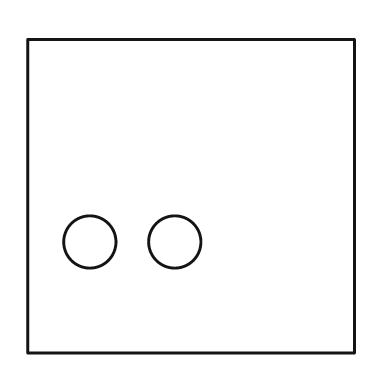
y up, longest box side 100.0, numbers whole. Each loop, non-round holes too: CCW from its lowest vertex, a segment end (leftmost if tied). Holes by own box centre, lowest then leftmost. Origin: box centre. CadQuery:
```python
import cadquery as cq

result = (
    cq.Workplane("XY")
    .moveTo(-50.0, -48.0)
    .lineTo(50.0, -48.0)
    .lineTo(50.0, 48.0)
    .lineTo(-50.0, 48.0)
    .close()
    .moveTo(-31.0, -14.0)
    .circle(8.0)
    .moveTo(-5.0, -14.0)
    .circle(8.0)
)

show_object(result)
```